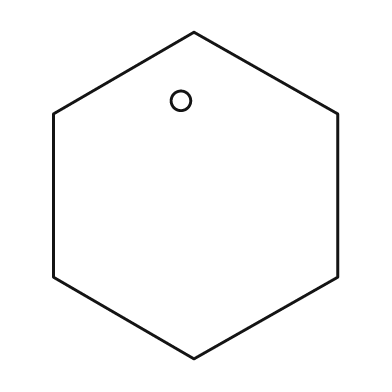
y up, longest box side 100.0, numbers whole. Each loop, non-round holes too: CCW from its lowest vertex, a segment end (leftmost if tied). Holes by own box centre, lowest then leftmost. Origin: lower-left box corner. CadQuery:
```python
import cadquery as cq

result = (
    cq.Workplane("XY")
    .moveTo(43.0, 0.0)
    .lineTo(87.0, 25.0)
    .lineTo(87.0, 75.0)
    .lineTo(43.0, 100.0)
    .lineTo(0.0, 75.0)
    .lineTo(0.0, 25.0)
    .close()
    .moveTo(39.0, 79.0)
    .circle(3.0)
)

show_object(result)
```